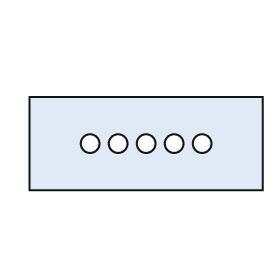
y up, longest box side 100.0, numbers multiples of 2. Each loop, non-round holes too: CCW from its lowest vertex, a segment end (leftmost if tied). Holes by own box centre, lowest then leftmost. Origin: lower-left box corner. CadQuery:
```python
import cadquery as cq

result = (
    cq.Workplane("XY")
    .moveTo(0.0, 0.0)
    .lineTo(100.0, 0.0)
    .lineTo(100.0, 40.0)
    .lineTo(0.0, 40.0)
    .close()
    .moveTo(26.0, 20.0)
    .circle(4.0)
    .moveTo(38.0, 20.0)
    .circle(4.0)
    .moveTo(50.0, 20.0)
    .circle(4.0)
    .moveTo(62.0, 20.0)
    .circle(4.0)
    .moveTo(74.0, 20.0)
    .circle(4.0)
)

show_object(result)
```